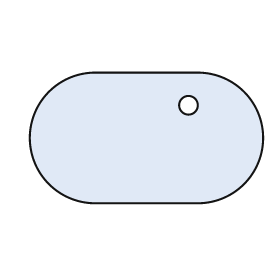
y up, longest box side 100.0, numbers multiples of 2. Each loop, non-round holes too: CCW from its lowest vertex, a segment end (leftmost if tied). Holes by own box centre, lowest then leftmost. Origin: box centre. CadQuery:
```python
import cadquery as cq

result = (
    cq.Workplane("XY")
    .moveTo(-22.0, -28.0)
    .lineTo(22.0, -28.0)
    .threePointArc((50.0, 0.0), (22.0, 28.0))
    .lineTo(-22.0, 28.0)
    .threePointArc((-50.0, 0.0), (-22.0, -28.0))
    .close()
    .moveTo(18.0, 14.0)
    .circle(4.0)
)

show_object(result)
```